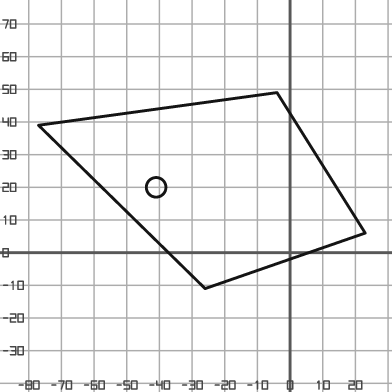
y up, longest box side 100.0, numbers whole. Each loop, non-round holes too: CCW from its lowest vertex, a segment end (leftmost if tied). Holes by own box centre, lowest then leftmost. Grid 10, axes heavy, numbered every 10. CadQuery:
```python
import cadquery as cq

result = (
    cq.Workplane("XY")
    .moveTo(-26.0, -11.0)
    .lineTo(23.0, 6.0)
    .lineTo(-4.0, 49.0)
    .lineTo(-77.0, 39.0)
    .close()
    .moveTo(-41.0, 20.0)
    .circle(3.0)
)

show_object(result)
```